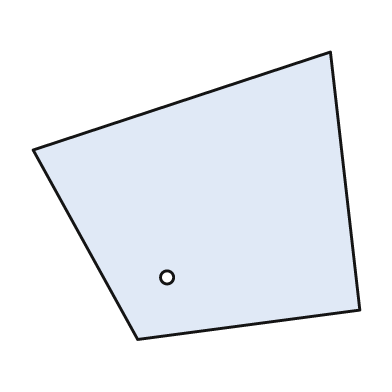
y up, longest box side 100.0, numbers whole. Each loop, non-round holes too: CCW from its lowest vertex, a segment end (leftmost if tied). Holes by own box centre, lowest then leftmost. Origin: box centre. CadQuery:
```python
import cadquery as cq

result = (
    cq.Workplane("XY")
    .moveTo(-18.0, -44.0)
    .lineTo(50.0, -35.0)
    .lineTo(41.0, 44.0)
    .lineTo(-50.0, 14.0)
    .close()
    .moveTo(-9.0, -25.0)
    .circle(2.0)
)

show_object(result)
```